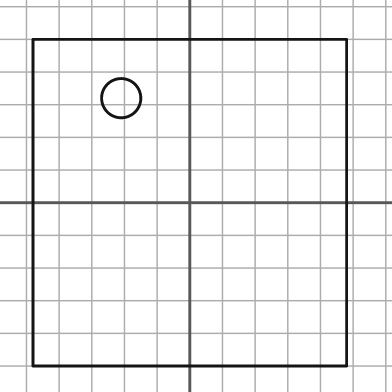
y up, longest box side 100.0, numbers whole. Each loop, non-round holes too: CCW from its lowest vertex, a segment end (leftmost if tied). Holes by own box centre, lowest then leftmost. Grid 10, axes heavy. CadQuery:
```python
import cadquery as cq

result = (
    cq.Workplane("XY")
    .moveTo(-48.0, -50.0)
    .lineTo(48.0, -50.0)
    .lineTo(48.0, 50.0)
    .lineTo(-48.0, 50.0)
    .close()
    .moveTo(-21.0, 32.0)
    .circle(6.0)
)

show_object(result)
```